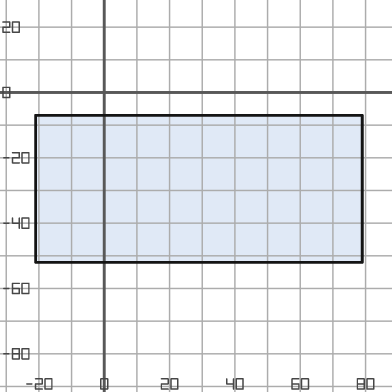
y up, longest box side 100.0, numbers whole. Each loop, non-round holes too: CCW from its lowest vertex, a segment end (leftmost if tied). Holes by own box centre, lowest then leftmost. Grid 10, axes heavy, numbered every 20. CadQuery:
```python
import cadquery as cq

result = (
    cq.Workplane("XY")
    .moveTo(-21.0, -52.0)
    .lineTo(79.0, -52.0)
    .lineTo(79.0, -7.0)
    .lineTo(-21.0, -7.0)
    .close()
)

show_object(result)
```